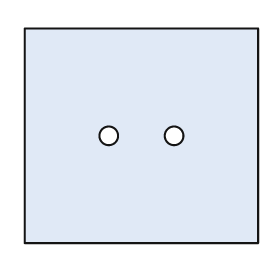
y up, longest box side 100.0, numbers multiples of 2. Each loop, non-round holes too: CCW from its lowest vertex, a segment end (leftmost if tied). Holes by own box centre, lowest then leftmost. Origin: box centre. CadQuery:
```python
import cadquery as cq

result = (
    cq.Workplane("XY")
    .moveTo(-50.0, -46.0)
    .lineTo(50.0, -46.0)
    .lineTo(50.0, 46.0)
    .lineTo(-50.0, 46.0)
    .close()
    .moveTo(-14.0, 0.0)
    .circle(4.0)
    .moveTo(14.0, 0.0)
    .circle(4.0)
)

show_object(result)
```